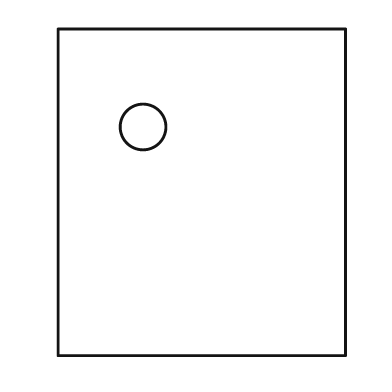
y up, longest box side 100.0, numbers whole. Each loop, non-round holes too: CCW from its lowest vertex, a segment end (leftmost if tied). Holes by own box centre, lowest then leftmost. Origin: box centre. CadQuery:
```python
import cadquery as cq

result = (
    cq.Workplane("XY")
    .moveTo(-44.0, -50.0)
    .lineTo(44.0, -50.0)
    .lineTo(44.0, 50.0)
    .lineTo(-44.0, 50.0)
    .close()
    .moveTo(-18.0, 20.0)
    .circle(7.0)
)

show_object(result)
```